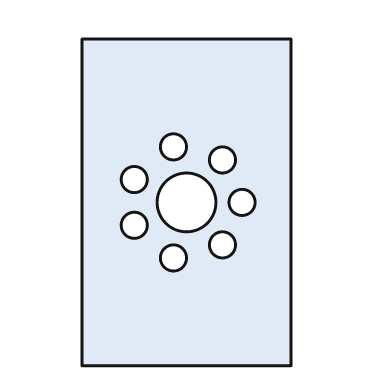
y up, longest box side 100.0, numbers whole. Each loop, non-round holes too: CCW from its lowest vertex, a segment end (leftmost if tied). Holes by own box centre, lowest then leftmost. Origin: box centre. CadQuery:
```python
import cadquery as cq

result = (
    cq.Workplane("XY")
    .moveTo(-32.0, -50.0)
    .lineTo(32.0, -50.0)
    .lineTo(32.0, 50.0)
    .lineTo(-32.0, 50.0)
    .close()
    .moveTo(-4.0, -17.0)
    .circle(4.0)
    .moveTo(11.0, -13.0)
    .circle(4.0)
    .moveTo(-16.0, -7.0)
    .circle(4.0)
    .moveTo(0.0, 0.0)
    .circle(9.0)
    .moveTo(17.0, 0.0)
    .circle(4.0)
    .moveTo(-16.0, 7.0)
    .circle(4.0)
    .moveTo(11.0, 13.0)
    .circle(4.0)
    .moveTo(-4.0, 17.0)
    .circle(4.0)
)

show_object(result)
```